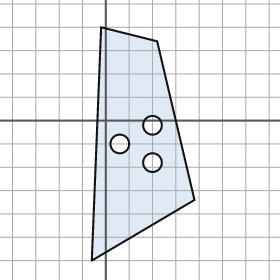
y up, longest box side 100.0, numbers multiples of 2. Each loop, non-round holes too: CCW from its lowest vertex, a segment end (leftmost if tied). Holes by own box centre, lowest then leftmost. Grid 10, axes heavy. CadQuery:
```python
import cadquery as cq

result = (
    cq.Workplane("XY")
    .moveTo(-6.0, -60.0)
    .lineTo(38.0, -34.0)
    .lineTo(22.0, 34.0)
    .lineTo(-2.0, 40.0)
    .close()
    .moveTo(20.0, -18.0)
    .circle(4.0)
    .moveTo(6.0, -10.0)
    .circle(4.0)
    .moveTo(20.0, -2.0)
    .circle(4.0)
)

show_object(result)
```